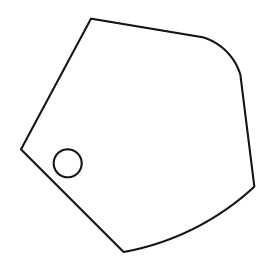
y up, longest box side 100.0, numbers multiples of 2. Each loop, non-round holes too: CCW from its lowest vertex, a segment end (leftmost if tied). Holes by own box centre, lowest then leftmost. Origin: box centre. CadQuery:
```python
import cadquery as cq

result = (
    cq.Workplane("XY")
    .moveTo(-6.0, -50.0)
    .threePointArc((24.0, -40.0), (50.0, -22.0))
    .lineTo(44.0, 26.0)
    .threePointArc((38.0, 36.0), (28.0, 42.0))
    .lineTo(-20.0, 50.0)
    .lineTo(-50.0, -6.0)
    .close()
    .moveTo(-30.0, -12.0)
    .circle(6.0)
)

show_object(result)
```